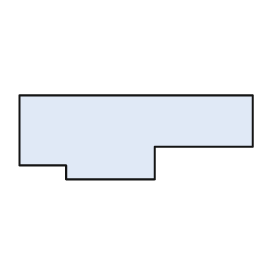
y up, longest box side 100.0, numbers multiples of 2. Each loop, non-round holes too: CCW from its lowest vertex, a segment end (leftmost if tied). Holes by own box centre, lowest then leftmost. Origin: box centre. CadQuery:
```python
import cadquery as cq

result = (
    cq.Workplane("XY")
    .moveTo(-30.0, -18.0)
    .lineTo(8.0, -18.0)
    .lineTo(8.0, -4.0)
    .lineTo(50.0, -4.0)
    .lineTo(50.0, 18.0)
    .lineTo(-50.0, 18.0)
    .lineTo(-50.0, -12.0)
    .lineTo(-30.0, -12.0)
    .close()
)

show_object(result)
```